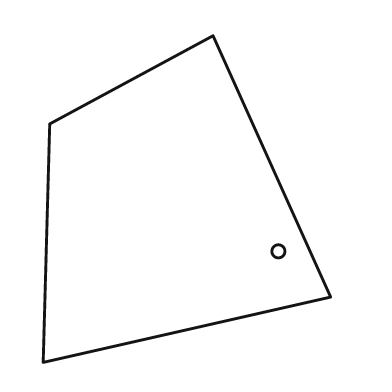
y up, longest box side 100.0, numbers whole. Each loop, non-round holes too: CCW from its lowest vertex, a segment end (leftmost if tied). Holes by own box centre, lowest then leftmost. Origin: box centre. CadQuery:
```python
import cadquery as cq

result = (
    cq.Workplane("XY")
    .moveTo(-44.0, -50.0)
    .lineTo(44.0, -30.0)
    .lineTo(8.0, 50.0)
    .lineTo(-42.0, 23.0)
    .close()
    .moveTo(28.0, -16.0)
    .circle(2.0)
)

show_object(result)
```